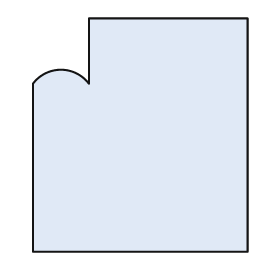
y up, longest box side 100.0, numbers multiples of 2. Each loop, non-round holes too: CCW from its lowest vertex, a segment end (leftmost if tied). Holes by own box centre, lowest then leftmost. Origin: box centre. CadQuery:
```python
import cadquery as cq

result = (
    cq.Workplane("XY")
    .moveTo(-46.0, -50.0)
    .lineTo(46.0, -50.0)
    .lineTo(46.0, 50.0)
    .lineTo(-22.0, 50.0)
    .lineTo(-22.0, 22.0)
    .threePointArc((-34.0, 28.0), (-46.0, 22.0))
    .close()
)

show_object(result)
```